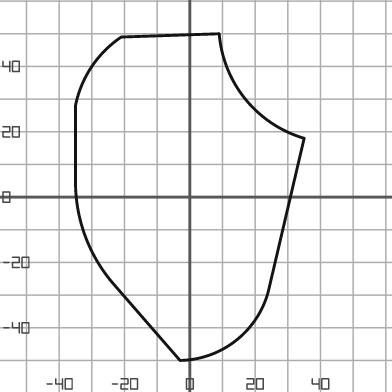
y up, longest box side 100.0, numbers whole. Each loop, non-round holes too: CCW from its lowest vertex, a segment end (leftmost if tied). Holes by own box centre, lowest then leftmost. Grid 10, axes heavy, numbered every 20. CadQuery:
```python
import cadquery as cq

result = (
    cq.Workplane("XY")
    .moveTo(-3.0, -50.0)
    .threePointArc((14.0, -44.0), (24.0, -29.0))
    .lineTo(35.0, 18.0)
    .threePointArc((17.0, 30.0), (9.0, 50.0))
    .lineTo(-21.0, 49.0)
    .threePointArc((-30.0, 40.0), (-35.0, 28.0))
    .lineTo(-35.0, 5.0)
    .threePointArc((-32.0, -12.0), (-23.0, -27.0))
    .close()
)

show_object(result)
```